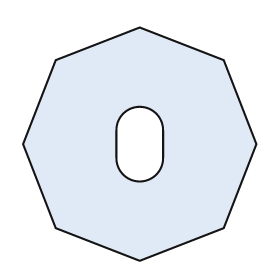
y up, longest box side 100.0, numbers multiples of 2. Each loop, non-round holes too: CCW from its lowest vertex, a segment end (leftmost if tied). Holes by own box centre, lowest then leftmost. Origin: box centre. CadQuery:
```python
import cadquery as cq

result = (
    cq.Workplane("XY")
    .moveTo(0.0, -50.0)
    .lineTo(36.0, -36.0)
    .lineTo(50.0, 0.0)
    .lineTo(36.0, 36.0)
    .lineTo(0.0, 50.0)
    .lineTo(-36.0, 36.0)
    .lineTo(-50.0, 0.0)
    .lineTo(-36.0, -36.0)
    .close()
    .moveTo(-10.0, -6.0)
    .threePointArc((0.0, -16.0), (10.0, -6.0))
    .lineTo(10.0, 6.0)
    .threePointArc((0.0, 16.0), (-10.0, 6.0))
    .close()
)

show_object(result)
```